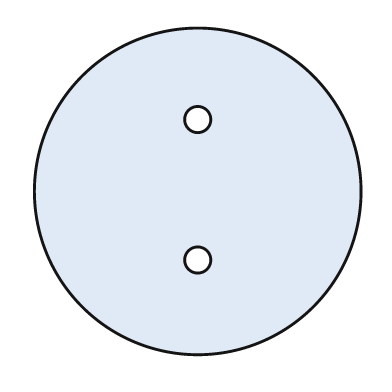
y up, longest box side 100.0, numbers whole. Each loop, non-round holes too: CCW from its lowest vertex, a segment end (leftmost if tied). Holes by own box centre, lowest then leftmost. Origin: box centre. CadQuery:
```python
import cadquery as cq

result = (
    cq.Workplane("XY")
    .moveTo(0.0, 0.0)
    .circle(50.0)
    .moveTo(0.0, -21.0)
    .circle(4.0)
    .moveTo(0.0, 22.0)
    .circle(4.0)
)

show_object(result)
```